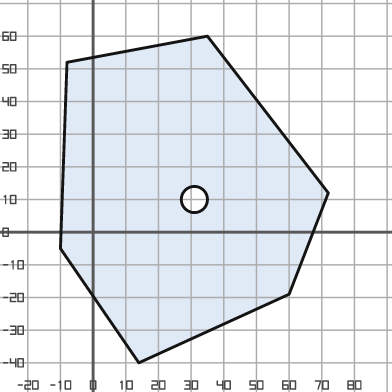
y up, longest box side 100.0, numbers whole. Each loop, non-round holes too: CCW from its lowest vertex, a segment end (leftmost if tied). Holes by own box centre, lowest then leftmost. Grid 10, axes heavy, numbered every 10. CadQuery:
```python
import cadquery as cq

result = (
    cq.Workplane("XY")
    .moveTo(14.0, -40.0)
    .lineTo(60.0, -19.0)
    .lineTo(72.0, 12.0)
    .lineTo(35.0, 60.0)
    .lineTo(-8.0, 52.0)
    .lineTo(-10.0, -5.0)
    .close()
    .moveTo(31.0, 10.0)
    .circle(4.0)
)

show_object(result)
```